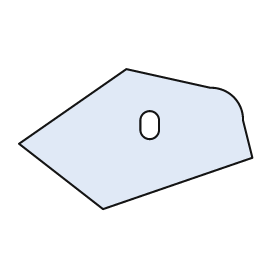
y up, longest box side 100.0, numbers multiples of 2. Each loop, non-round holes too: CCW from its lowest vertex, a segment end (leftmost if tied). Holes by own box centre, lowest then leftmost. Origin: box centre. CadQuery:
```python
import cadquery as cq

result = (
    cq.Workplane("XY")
    .moveTo(-14.0, -30.0)
    .lineTo(50.0, -8.0)
    .lineTo(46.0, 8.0)
    .threePointArc((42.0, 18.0), (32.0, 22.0))
    .lineTo(-4.0, 30.0)
    .lineTo(-50.0, -2.0)
    .close()
    .moveTo(2.0, 4.0)
    .threePointArc((6.0, 0.0), (10.0, 4.0))
    .lineTo(10.0, 8.0)
    .threePointArc((6.0, 12.0), (2.0, 8.0))
    .close()
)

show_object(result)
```